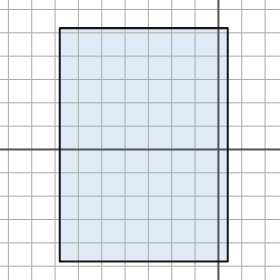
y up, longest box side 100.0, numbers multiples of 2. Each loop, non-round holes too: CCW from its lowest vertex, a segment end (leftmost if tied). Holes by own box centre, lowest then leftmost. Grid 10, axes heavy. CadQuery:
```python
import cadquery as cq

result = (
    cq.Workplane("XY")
    .moveTo(-68.0, -48.0)
    .lineTo(4.0, -48.0)
    .lineTo(4.0, 52.0)
    .lineTo(-68.0, 52.0)
    .close()
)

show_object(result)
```